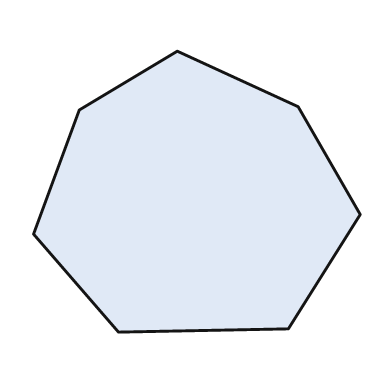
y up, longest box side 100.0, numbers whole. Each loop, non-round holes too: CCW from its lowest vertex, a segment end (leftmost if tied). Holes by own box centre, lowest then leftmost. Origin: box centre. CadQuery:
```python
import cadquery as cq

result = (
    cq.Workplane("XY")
    .moveTo(-24.0, -43.0)
    .lineTo(28.0, -42.0)
    .lineTo(50.0, -7.0)
    .lineTo(31.0, 26.0)
    .lineTo(-6.0, 43.0)
    .lineTo(-36.0, 25.0)
    .lineTo(-50.0, -13.0)
    .close()
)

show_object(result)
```